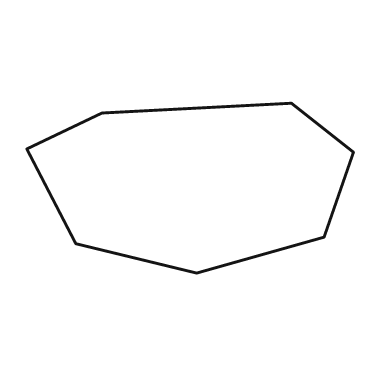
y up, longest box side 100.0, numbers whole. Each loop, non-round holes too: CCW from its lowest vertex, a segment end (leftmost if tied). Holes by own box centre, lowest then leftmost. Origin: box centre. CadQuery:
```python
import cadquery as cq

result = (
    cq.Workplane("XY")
    .moveTo(2.0, -26.0)
    .lineTo(41.0, -15.0)
    .lineTo(50.0, 11.0)
    .lineTo(31.0, 26.0)
    .lineTo(-27.0, 23.0)
    .lineTo(-50.0, 12.0)
    .lineTo(-35.0, -17.0)
    .close()
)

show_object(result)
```